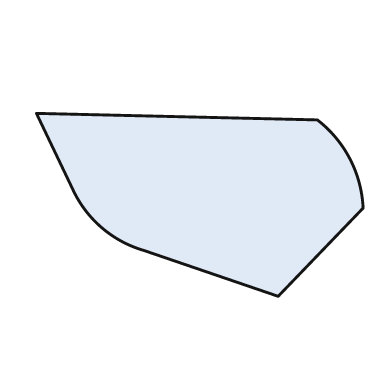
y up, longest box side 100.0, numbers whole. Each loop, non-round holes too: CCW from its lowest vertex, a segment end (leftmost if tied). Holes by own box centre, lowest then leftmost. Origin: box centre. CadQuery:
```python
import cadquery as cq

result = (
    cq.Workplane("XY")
    .moveTo(24.0, -28.0)
    .lineTo(50.0, -1.0)
    .threePointArc((46.0, 14.0), (36.0, 26.0))
    .lineTo(-50.0, 28.0)
    .lineTo(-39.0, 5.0)
    .threePointArc((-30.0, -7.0), (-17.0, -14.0))
    .close()
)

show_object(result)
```